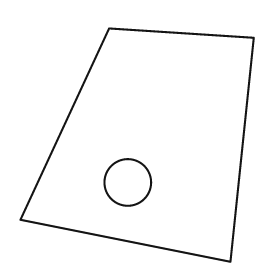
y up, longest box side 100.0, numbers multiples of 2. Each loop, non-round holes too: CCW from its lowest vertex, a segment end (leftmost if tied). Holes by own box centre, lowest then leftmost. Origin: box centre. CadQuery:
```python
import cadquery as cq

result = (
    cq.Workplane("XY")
    .moveTo(40.0, -50.0)
    .lineTo(50.0, 46.0)
    .lineTo(-12.0, 50.0)
    .lineTo(-50.0, -32.0)
    .close()
    .moveTo(-4.0, -16.0)
    .circle(10.0)
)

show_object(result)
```